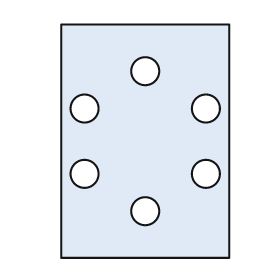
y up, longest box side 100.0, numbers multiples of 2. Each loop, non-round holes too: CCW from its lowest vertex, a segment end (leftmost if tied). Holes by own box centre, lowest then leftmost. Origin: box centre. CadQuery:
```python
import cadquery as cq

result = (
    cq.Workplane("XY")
    .moveTo(-36.0, -50.0)
    .lineTo(36.0, -50.0)
    .lineTo(36.0, 50.0)
    .lineTo(-36.0, 50.0)
    .close()
    .moveTo(0.0, -30.0)
    .circle(6.0)
    .moveTo(-26.0, -14.0)
    .circle(6.0)
    .moveTo(26.0, -14.0)
    .circle(6.0)
    .moveTo(-26.0, 14.0)
    .circle(6.0)
    .moveTo(26.0, 14.0)
    .circle(6.0)
    .moveTo(0.0, 30.0)
    .circle(6.0)
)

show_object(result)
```